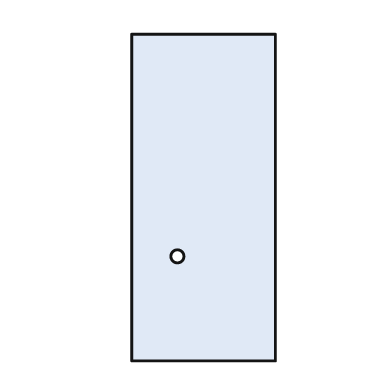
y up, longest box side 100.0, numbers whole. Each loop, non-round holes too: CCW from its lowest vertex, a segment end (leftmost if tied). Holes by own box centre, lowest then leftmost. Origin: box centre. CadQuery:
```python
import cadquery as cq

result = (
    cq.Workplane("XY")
    .moveTo(-22.0, -50.0)
    .lineTo(22.0, -50.0)
    .lineTo(22.0, 50.0)
    .lineTo(-22.0, 50.0)
    .close()
    .moveTo(-8.0, -18.0)
    .circle(2.0)
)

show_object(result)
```